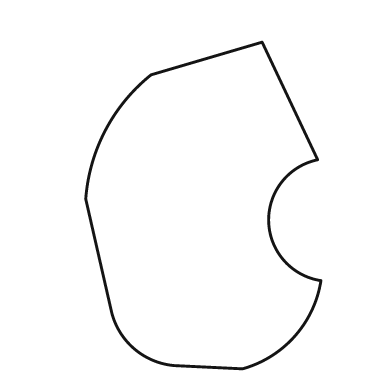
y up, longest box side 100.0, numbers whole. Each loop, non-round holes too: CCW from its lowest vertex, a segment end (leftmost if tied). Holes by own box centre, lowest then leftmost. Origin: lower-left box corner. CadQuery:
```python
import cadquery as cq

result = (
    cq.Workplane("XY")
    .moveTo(48.0, 0.0)
    .threePointArc((64.0, 10.0), (72.0, 27.0))
    .threePointArc((56.0, 45.0), (71.0, 64.0))
    .lineTo(54.0, 100.0)
    .lineTo(20.0, 90.0)
    .threePointArc((6.0, 73.0), (0.0, 52.0))
    .lineTo(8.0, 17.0)
    .threePointArc((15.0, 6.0), (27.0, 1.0))
    .close()
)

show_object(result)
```